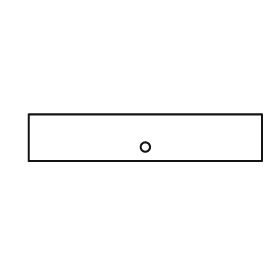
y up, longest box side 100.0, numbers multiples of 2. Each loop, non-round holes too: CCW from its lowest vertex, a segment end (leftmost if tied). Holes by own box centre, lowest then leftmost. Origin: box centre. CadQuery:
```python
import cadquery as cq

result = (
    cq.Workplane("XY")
    .moveTo(-50.0, -10.0)
    .lineTo(50.0, -10.0)
    .lineTo(50.0, 10.0)
    .lineTo(-50.0, 10.0)
    .close()
    .moveTo(0.0, -4.0)
    .circle(2.0)
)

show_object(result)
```